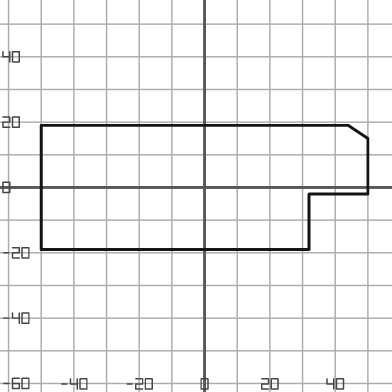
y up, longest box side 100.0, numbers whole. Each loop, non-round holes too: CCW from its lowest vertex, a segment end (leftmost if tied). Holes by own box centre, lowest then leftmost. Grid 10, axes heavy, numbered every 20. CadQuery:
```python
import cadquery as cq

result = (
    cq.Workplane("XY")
    .moveTo(-50.0, -19.0)
    .lineTo(32.0, -19.0)
    .lineTo(32.0, -2.0)
    .lineTo(50.0, -2.0)
    .lineTo(50.0, 15.0)
    .lineTo(44.0, 19.0)
    .lineTo(-50.0, 19.0)
    .close()
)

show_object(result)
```